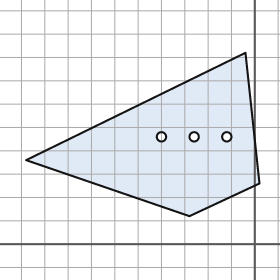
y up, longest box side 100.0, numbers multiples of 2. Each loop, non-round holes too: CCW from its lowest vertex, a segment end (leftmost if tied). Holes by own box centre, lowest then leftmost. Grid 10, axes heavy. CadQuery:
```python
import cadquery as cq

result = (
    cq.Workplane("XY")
    .moveTo(-28.0, 12.0)
    .lineTo(2.0, 26.0)
    .lineTo(-4.0, 82.0)
    .lineTo(-98.0, 36.0)
    .close()
    .moveTo(-40.0, 46.0)
    .circle(2.0)
    .moveTo(-26.0, 46.0)
    .circle(2.0)
    .moveTo(-12.0, 46.0)
    .circle(2.0)
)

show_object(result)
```